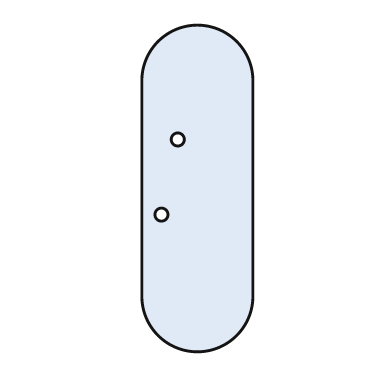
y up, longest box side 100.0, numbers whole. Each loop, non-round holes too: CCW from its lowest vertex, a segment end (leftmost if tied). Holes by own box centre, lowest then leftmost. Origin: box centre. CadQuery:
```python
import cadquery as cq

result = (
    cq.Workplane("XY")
    .moveTo(-17.0, -33.0)
    .threePointArc((0.0, -50.0), (17.0, -33.0))
    .lineTo(17.0, 33.0)
    .threePointArc((0.0, 50.0), (-17.0, 33.0))
    .close()
    .moveTo(-11.0, -8.0)
    .circle(2.0)
    .moveTo(-6.0, 15.0)
    .circle(2.0)
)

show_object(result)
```